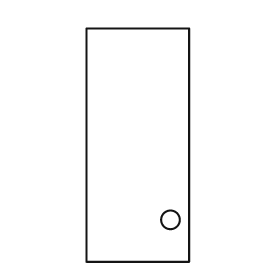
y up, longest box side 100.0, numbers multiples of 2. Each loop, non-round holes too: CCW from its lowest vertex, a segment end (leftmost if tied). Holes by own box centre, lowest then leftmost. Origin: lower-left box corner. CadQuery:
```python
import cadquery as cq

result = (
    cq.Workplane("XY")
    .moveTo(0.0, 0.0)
    .lineTo(44.0, 0.0)
    .lineTo(44.0, 100.0)
    .lineTo(0.0, 100.0)
    .close()
    .moveTo(36.0, 18.0)
    .circle(4.0)
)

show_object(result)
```